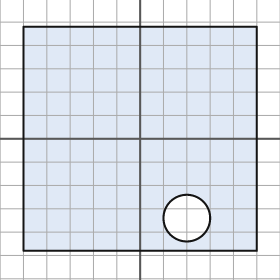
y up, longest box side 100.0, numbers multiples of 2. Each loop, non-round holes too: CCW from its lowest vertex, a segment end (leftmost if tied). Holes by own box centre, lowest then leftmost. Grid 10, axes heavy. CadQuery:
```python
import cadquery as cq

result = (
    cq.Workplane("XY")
    .moveTo(-50.0, -48.0)
    .lineTo(50.0, -48.0)
    .lineTo(50.0, 48.0)
    .lineTo(-50.0, 48.0)
    .close()
    .moveTo(20.0, -34.0)
    .circle(10.0)
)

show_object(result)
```